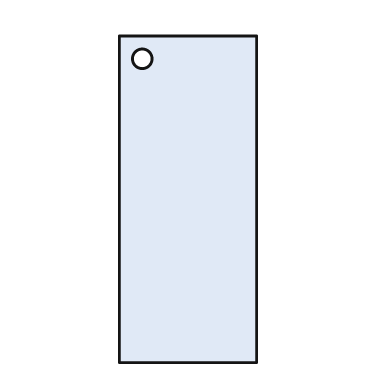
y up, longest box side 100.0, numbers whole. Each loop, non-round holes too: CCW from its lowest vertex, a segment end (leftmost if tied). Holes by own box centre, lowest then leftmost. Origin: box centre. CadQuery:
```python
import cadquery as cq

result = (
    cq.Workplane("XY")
    .moveTo(-21.0, -50.0)
    .lineTo(21.0, -50.0)
    .lineTo(21.0, 50.0)
    .lineTo(-21.0, 50.0)
    .close()
    .moveTo(-14.0, 43.0)
    .circle(3.0)
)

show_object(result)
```